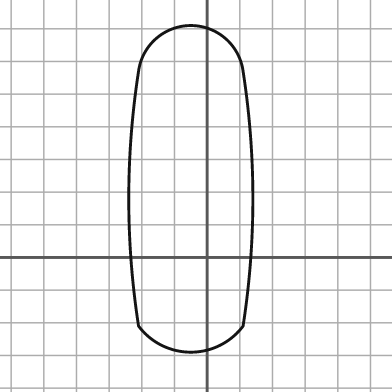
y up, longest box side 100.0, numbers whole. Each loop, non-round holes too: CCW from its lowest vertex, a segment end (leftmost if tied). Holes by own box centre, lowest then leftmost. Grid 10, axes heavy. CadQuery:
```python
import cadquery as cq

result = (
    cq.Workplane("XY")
    .moveTo(-21.0, -21.0)
    .threePointArc((-5.0, -29.0), (11.0, -21.0))
    .threePointArc((14.0, 18.0), (11.0, 57.0))
    .threePointArc((-5.0, 71.0), (-21.0, 57.0))
    .threePointArc((-24.0, 18.0), (-21.0, -21.0))
    .close()
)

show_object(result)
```